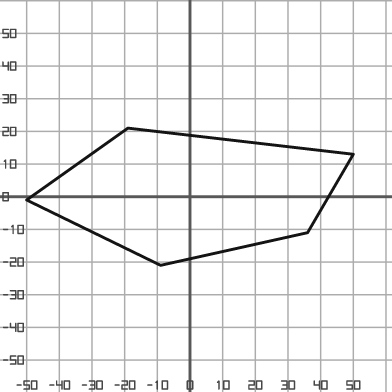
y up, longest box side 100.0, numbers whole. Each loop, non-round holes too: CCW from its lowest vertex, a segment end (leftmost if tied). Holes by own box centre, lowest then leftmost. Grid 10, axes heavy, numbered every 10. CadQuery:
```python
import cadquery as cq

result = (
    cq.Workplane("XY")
    .moveTo(-9.0, -21.0)
    .lineTo(36.0, -11.0)
    .lineTo(50.0, 13.0)
    .lineTo(-19.0, 21.0)
    .lineTo(-50.0, -1.0)
    .close()
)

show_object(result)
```